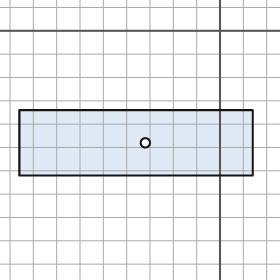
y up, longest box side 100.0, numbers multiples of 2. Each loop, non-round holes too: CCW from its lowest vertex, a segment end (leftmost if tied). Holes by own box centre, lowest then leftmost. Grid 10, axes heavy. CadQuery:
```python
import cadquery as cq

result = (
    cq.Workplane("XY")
    .moveTo(-86.0, -62.0)
    .lineTo(14.0, -62.0)
    .lineTo(14.0, -34.0)
    .lineTo(-86.0, -34.0)
    .close()
    .moveTo(-32.0, -48.0)
    .circle(2.0)
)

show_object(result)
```